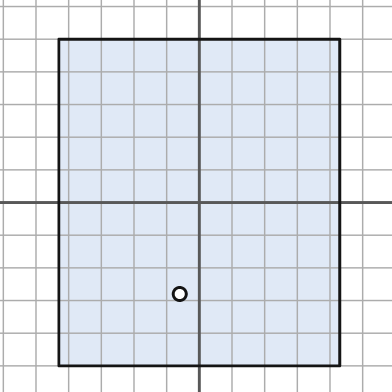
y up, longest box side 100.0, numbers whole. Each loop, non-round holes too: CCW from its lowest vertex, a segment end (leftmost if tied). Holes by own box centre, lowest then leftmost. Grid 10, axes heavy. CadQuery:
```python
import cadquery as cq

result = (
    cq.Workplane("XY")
    .moveTo(-43.0, -50.0)
    .lineTo(43.0, -50.0)
    .lineTo(43.0, 50.0)
    .lineTo(-43.0, 50.0)
    .close()
    .moveTo(-6.0, -28.0)
    .circle(2.0)
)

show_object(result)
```